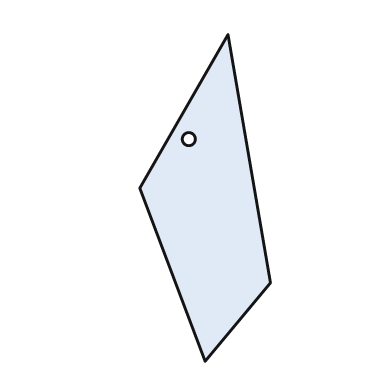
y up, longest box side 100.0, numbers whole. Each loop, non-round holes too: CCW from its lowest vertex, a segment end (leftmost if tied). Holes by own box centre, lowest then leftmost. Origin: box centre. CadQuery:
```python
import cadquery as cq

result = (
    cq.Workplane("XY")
    .moveTo(0.0, -50.0)
    .lineTo(20.0, -26.0)
    .lineTo(7.0, 50.0)
    .lineTo(-20.0, 3.0)
    .close()
    .moveTo(-5.0, 18.0)
    .circle(2.0)
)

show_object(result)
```